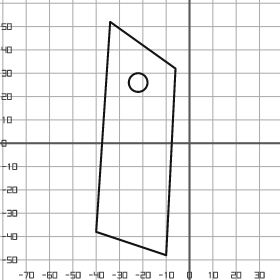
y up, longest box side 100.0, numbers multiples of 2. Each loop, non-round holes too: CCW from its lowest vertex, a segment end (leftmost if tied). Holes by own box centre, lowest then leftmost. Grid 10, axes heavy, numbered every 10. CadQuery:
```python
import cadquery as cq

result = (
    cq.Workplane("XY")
    .moveTo(-10.0, -48.0)
    .lineTo(-6.0, 32.0)
    .lineTo(-34.0, 52.0)
    .lineTo(-40.0, -38.0)
    .close()
    .moveTo(-22.0, 26.0)
    .circle(4.0)
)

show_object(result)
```